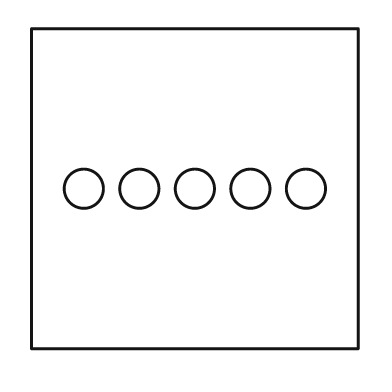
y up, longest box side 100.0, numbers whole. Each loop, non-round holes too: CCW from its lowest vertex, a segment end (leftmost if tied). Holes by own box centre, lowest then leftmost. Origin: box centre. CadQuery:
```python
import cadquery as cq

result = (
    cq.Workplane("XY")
    .moveTo(-50.0, -49.0)
    .lineTo(50.0, -49.0)
    .lineTo(50.0, 49.0)
    .lineTo(-50.0, 49.0)
    .close()
    .moveTo(-34.0, 0.0)
    .circle(6.0)
    .moveTo(-17.0, 0.0)
    .circle(6.0)
    .moveTo(0.0, 0.0)
    .circle(6.0)
    .moveTo(17.0, 0.0)
    .circle(6.0)
    .moveTo(34.0, 0.0)
    .circle(6.0)
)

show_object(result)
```